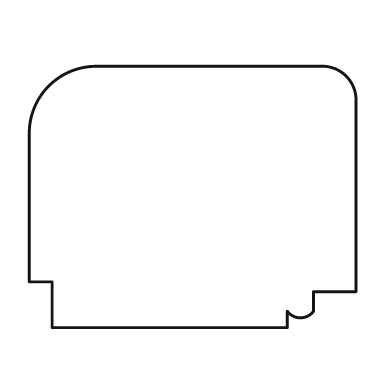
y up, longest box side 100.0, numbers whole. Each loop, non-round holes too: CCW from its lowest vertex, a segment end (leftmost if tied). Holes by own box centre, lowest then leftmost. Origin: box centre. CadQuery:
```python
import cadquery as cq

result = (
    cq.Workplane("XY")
    .moveTo(-43.0, -40.0)
    .lineTo(29.0, -40.0)
    .lineTo(29.0, -35.0)
    .threePointArc((33.0, -37.0), (37.0, -35.0))
    .lineTo(37.0, -29.0)
    .lineTo(50.0, -29.0)
    .lineTo(50.0, 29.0)
    .threePointArc((47.0, 37.0), (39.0, 40.0))
    .lineTo(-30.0, 40.0)
    .threePointArc((-44.0, 34.0), (-50.0, 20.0))
    .lineTo(-50.0, -26.0)
    .lineTo(-43.0, -26.0)
    .close()
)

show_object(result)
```